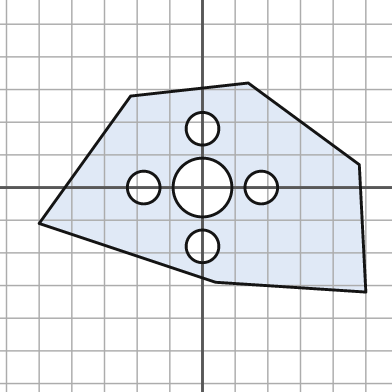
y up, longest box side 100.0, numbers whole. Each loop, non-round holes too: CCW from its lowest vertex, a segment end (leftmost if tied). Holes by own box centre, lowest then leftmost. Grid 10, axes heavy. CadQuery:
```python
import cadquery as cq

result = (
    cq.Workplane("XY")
    .moveTo(50.0, -32.0)
    .lineTo(48.0, 7.0)
    .lineTo(14.0, 32.0)
    .lineTo(-22.0, 28.0)
    .lineTo(-50.0, -11.0)
    .lineTo(4.0, -29.0)
    .close()
    .moveTo(0.0, -18.0)
    .circle(5.0)
    .moveTo(-18.0, 0.0)
    .circle(5.0)
    .moveTo(0.0, 0.0)
    .circle(9.0)
    .moveTo(18.0, 0.0)
    .circle(5.0)
    .moveTo(0.0, 18.0)
    .circle(5.0)
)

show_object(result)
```